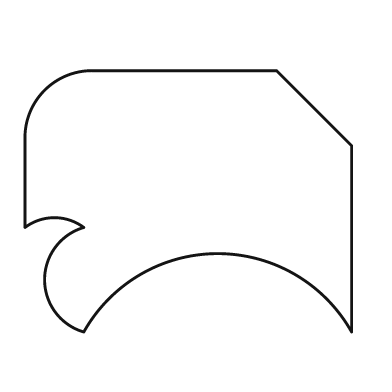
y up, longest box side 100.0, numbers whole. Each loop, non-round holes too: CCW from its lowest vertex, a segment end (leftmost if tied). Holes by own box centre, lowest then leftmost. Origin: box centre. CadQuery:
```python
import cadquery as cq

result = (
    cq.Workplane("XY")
    .moveTo(-32.0, -40.0)
    .threePointArc((9.0, -16.0), (50.0, -40.0))
    .lineTo(50.0, 17.0)
    .lineTo(27.0, 40.0)
    .lineTo(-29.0, 40.0)
    .threePointArc((-44.0, 34.0), (-50.0, 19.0))
    .lineTo(-50.0, -8.0)
    .threePointArc((-41.0, -5.0), (-32.0, -8.0))
    .threePointArc((-44.0, -24.0), (-32.0, -40.0))
    .close()
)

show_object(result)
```